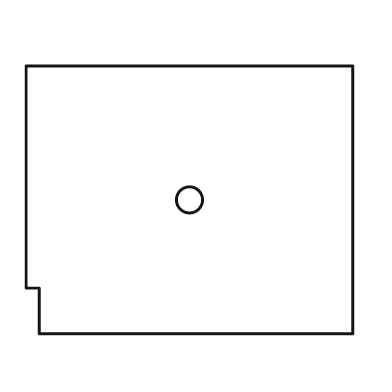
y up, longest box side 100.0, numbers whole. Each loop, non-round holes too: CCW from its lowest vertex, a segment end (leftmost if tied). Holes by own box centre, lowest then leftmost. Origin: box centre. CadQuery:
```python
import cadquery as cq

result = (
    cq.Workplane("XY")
    .moveTo(-46.0, -41.0)
    .lineTo(50.0, -41.0)
    .lineTo(50.0, 41.0)
    .lineTo(-50.0, 41.0)
    .lineTo(-50.0, -27.0)
    .lineTo(-46.0, -27.0)
    .close()
    .moveTo(0.0, 0.0)
    .circle(4.0)
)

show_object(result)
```